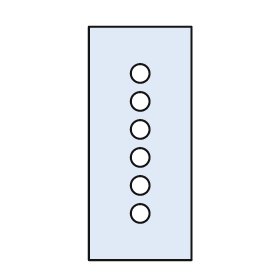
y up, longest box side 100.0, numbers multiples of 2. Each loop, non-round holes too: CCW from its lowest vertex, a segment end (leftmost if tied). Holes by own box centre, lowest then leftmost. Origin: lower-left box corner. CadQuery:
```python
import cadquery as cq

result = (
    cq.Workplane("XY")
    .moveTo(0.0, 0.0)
    .lineTo(44.0, 0.0)
    .lineTo(44.0, 100.0)
    .lineTo(0.0, 100.0)
    .close()
    .moveTo(22.0, 20.0)
    .circle(4.0)
    .moveTo(22.0, 32.0)
    .circle(4.0)
    .moveTo(22.0, 44.0)
    .circle(4.0)
    .moveTo(22.0, 56.0)
    .circle(4.0)
    .moveTo(22.0, 68.0)
    .circle(4.0)
    .moveTo(22.0, 80.0)
    .circle(4.0)
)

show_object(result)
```